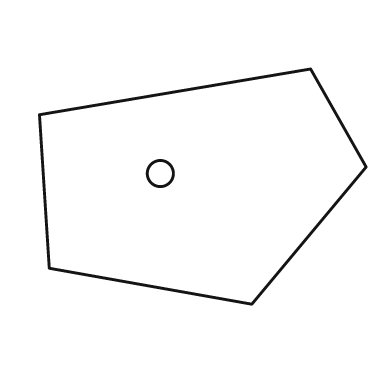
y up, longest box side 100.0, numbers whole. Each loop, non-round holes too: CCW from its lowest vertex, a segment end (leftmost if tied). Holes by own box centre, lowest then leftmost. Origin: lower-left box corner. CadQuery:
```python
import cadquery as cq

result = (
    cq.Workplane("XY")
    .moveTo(65.0, 0.0)
    .lineTo(100.0, 42.0)
    .lineTo(83.0, 72.0)
    .lineTo(0.0, 58.0)
    .lineTo(3.0, 11.0)
    .close()
    .moveTo(37.0, 40.0)
    .circle(4.0)
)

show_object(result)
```